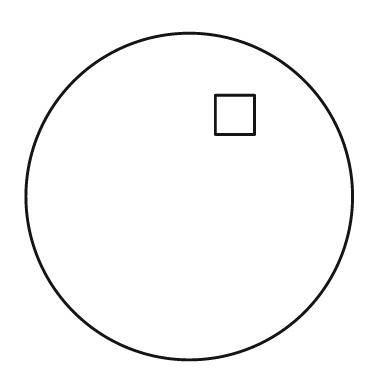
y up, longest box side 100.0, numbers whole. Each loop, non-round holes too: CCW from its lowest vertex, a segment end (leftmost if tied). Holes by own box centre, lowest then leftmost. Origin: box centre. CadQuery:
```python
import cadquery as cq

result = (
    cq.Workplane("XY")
    .moveTo(0.0, 0.0)
    .circle(50.0)
    .moveTo(8.0, 19.0)
    .lineTo(20.0, 19.0)
    .lineTo(20.0, 31.0)
    .lineTo(8.0, 31.0)
    .close()
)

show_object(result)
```